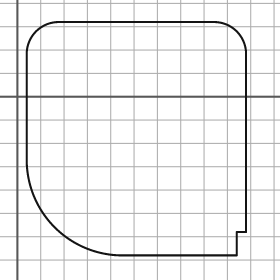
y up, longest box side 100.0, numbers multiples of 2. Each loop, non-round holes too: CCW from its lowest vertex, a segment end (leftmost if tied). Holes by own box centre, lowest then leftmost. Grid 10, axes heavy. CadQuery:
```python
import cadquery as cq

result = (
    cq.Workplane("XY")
    .moveTo(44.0, -68.0)
    .lineTo(94.0, -68.0)
    .lineTo(94.0, -58.0)
    .lineTo(98.0, -58.0)
    .lineTo(98.0, 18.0)
    .threePointArc((94.0, 28.0), (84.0, 32.0))
    .lineTo(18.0, 32.0)
    .threePointArc((8.0, 28.0), (4.0, 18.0))
    .lineTo(4.0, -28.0)
    .threePointArc((16.0, -56.0), (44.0, -68.0))
    .close()
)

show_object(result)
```